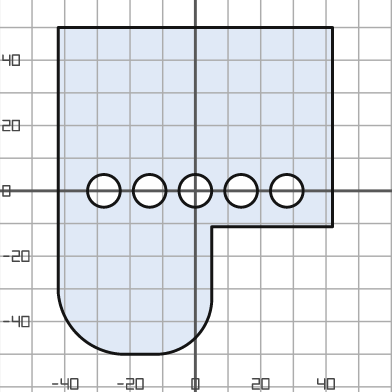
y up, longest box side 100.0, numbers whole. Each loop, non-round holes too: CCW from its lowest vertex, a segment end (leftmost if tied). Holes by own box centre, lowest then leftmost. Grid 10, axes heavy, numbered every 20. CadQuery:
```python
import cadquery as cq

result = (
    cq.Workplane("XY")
    .moveTo(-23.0, -50.0)
    .lineTo(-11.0, -50.0)
    .threePointArc((0.0, -45.0), (5.0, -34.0))
    .lineTo(5.0, -11.0)
    .lineTo(42.0, -11.0)
    .lineTo(42.0, 50.0)
    .lineTo(-42.0, 50.0)
    .lineTo(-42.0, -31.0)
    .threePointArc((-36.0, -44.0), (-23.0, -50.0))
    .close()
    .moveTo(-28.0, 0.0)
    .circle(5.0)
    .moveTo(-14.0, 0.0)
    .circle(5.0)
    .moveTo(0.0, 0.0)
    .circle(5.0)
    .moveTo(14.0, 0.0)
    .circle(5.0)
    .moveTo(28.0, 0.0)
    .circle(5.0)
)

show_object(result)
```